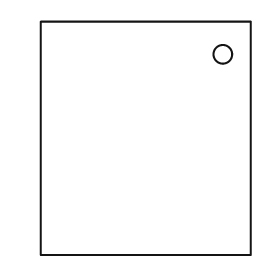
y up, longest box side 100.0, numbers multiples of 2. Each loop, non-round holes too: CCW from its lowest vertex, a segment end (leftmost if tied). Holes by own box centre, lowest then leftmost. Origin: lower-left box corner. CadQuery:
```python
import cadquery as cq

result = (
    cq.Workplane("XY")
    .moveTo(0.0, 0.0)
    .lineTo(90.0, 0.0)
    .lineTo(90.0, 100.0)
    .lineTo(0.0, 100.0)
    .close()
    .moveTo(78.0, 86.0)
    .circle(4.0)
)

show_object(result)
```